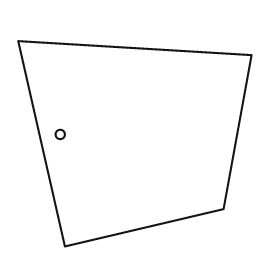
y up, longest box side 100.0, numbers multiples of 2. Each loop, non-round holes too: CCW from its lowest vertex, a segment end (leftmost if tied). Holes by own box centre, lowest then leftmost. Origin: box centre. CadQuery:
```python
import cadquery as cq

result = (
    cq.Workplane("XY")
    .moveTo(-30.0, -44.0)
    .lineTo(38.0, -28.0)
    .lineTo(50.0, 38.0)
    .lineTo(-50.0, 44.0)
    .close()
    .moveTo(-32.0, 4.0)
    .circle(2.0)
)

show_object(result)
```